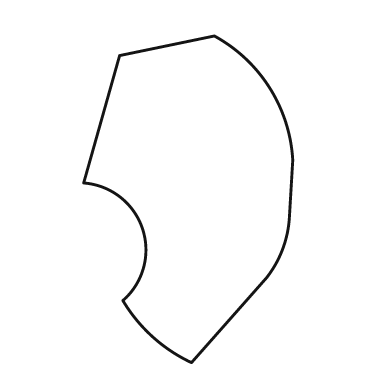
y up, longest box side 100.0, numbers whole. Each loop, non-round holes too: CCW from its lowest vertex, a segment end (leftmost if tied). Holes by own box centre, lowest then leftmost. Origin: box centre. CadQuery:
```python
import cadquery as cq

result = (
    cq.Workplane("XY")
    .moveTo(1.0, -50.0)
    .lineTo(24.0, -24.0)
    .threePointArc((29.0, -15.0), (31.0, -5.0))
    .lineTo(32.0, 12.0)
    .threePointArc((25.0, 34.0), (8.0, 50.0))
    .lineTo(-21.0, 44.0)
    .lineTo(-32.0, 5.0)
    .threePointArc((-14.0, -9.0), (-20.0, -31.0))
    .threePointArc((-11.0, -42.0), (1.0, -50.0))
    .close()
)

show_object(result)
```